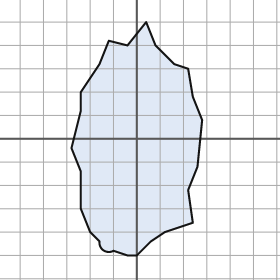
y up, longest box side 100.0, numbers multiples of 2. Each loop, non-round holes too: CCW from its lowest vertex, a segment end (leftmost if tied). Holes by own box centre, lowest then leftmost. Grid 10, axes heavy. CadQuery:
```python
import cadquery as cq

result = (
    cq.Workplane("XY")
    .moveTo(-4.0, -50.0)
    .lineTo(0.0, -50.0)
    .lineTo(6.0, -44.0)
    .lineTo(12.0, -40.0)
    .lineTo(24.0, -36.0)
    .lineTo(22.0, -22.0)
    .lineTo(26.0, -12.0)
    .lineTo(28.0, 8.0)
    .lineTo(24.0, 18.0)
    .lineTo(22.0, 30.0)
    .lineTo(16.0, 32.0)
    .lineTo(8.0, 40.0)
    .lineTo(4.0, 50.0)
    .lineTo(-4.0, 40.0)
    .lineTo(-12.0, 42.0)
    .lineTo(-16.0, 32.0)
    .lineTo(-24.0, 20.0)
    .lineTo(-24.0, 12.0)
    .lineTo(-28.0, -4.0)
    .lineTo(-24.0, -14.0)
    .lineTo(-24.0, -30.0)
    .lineTo(-20.0, -40.0)
    .lineTo(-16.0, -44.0)
    .threePointArc((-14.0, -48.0), (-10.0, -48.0))
    .close()
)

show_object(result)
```